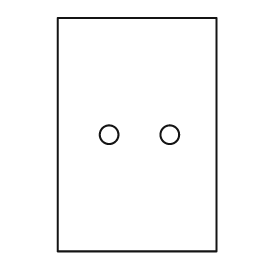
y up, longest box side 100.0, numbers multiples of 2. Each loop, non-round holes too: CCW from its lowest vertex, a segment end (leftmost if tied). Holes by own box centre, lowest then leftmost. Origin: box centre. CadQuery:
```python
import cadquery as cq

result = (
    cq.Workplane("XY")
    .moveTo(-34.0, -50.0)
    .lineTo(34.0, -50.0)
    .lineTo(34.0, 50.0)
    .lineTo(-34.0, 50.0)
    .close()
    .moveTo(-12.0, 0.0)
    .circle(4.0)
    .moveTo(14.0, 0.0)
    .circle(4.0)
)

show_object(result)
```